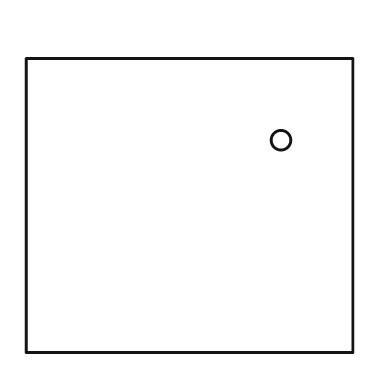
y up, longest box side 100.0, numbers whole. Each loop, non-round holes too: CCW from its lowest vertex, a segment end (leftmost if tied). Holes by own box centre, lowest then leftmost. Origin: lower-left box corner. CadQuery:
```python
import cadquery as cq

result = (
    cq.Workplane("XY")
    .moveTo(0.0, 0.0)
    .lineTo(100.0, 0.0)
    .lineTo(100.0, 90.0)
    .lineTo(0.0, 90.0)
    .close()
    .moveTo(78.0, 65.0)
    .circle(3.0)
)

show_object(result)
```